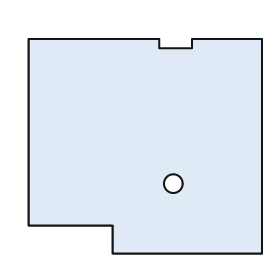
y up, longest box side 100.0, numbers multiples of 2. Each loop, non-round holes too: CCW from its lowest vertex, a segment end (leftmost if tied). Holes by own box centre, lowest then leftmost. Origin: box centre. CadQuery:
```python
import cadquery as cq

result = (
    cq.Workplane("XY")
    .moveTo(-14.0, -46.0)
    .lineTo(50.0, -46.0)
    .lineTo(50.0, 46.0)
    .lineTo(20.0, 46.0)
    .lineTo(20.0, 42.0)
    .lineTo(6.0, 42.0)
    .lineTo(6.0, 46.0)
    .lineTo(-50.0, 46.0)
    .lineTo(-50.0, -34.0)
    .lineTo(-14.0, -34.0)
    .close()
    .moveTo(12.0, -16.0)
    .circle(4.0)
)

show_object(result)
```